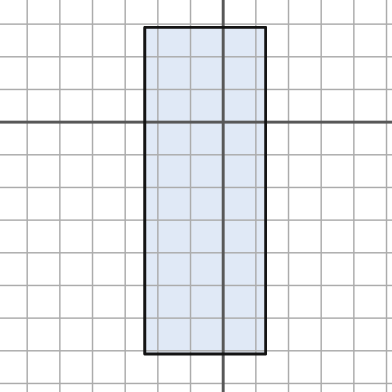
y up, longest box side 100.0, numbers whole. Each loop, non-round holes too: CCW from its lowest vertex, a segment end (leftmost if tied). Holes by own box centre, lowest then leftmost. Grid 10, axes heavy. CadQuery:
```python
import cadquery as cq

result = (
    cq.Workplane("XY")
    .moveTo(-24.0, -71.0)
    .lineTo(13.0, -71.0)
    .lineTo(13.0, 29.0)
    .lineTo(-24.0, 29.0)
    .close()
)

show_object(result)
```